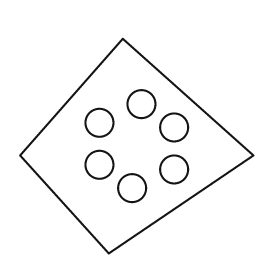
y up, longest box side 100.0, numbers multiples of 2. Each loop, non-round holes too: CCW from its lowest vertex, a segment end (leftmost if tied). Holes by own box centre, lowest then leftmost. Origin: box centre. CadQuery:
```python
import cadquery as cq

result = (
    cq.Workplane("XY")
    .moveTo(-12.0, -46.0)
    .lineTo(50.0, -4.0)
    .lineTo(-6.0, 46.0)
    .lineTo(-50.0, -4.0)
    .close()
    .moveTo(-2.0, -18.0)
    .circle(6.0)
    .moveTo(16.0, -10.0)
    .circle(6.0)
    .moveTo(-16.0, -8.0)
    .circle(6.0)
    .moveTo(16.0, 8.0)
    .circle(6.0)
    .moveTo(-16.0, 10.0)
    .circle(6.0)
    .moveTo(2.0, 18.0)
    .circle(6.0)
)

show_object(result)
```